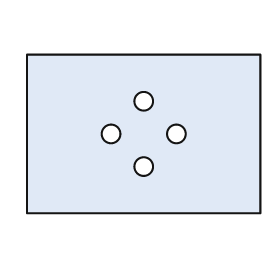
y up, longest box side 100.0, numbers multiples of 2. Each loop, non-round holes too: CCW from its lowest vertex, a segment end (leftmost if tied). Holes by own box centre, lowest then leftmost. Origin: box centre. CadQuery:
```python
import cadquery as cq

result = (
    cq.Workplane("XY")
    .moveTo(-50.0, -34.0)
    .lineTo(50.0, -34.0)
    .lineTo(50.0, 34.0)
    .lineTo(-50.0, 34.0)
    .close()
    .moveTo(0.0, -14.0)
    .circle(4.0)
    .moveTo(-14.0, 0.0)
    .circle(4.0)
    .moveTo(14.0, 0.0)
    .circle(4.0)
    .moveTo(0.0, 14.0)
    .circle(4.0)
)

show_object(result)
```